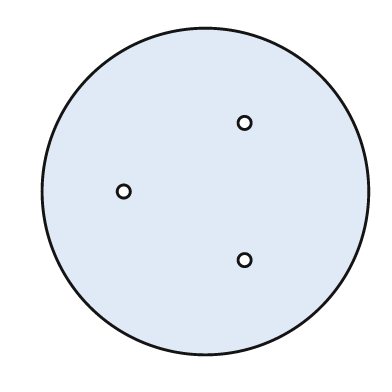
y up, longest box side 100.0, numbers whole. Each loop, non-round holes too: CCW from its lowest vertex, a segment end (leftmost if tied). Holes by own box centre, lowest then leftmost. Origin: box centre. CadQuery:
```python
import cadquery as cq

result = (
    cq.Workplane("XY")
    .moveTo(0.0, 0.0)
    .circle(50.0)
    .moveTo(12.0, -21.0)
    .circle(2.0)
    .moveTo(-25.0, 0.0)
    .circle(2.0)
    .moveTo(12.0, 21.0)
    .circle(2.0)
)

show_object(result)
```